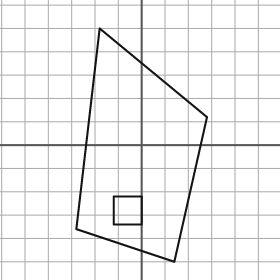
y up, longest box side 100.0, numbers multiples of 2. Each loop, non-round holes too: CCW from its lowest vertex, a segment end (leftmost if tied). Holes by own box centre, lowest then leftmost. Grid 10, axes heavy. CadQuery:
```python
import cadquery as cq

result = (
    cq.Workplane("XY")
    .moveTo(14.0, -50.0)
    .lineTo(28.0, 12.0)
    .lineTo(-18.0, 50.0)
    .lineTo(-28.0, -36.0)
    .close()
    .moveTo(-12.0, -34.0)
    .lineTo(0.0, -34.0)
    .lineTo(0.0, -22.0)
    .lineTo(-12.0, -22.0)
    .close()
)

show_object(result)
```